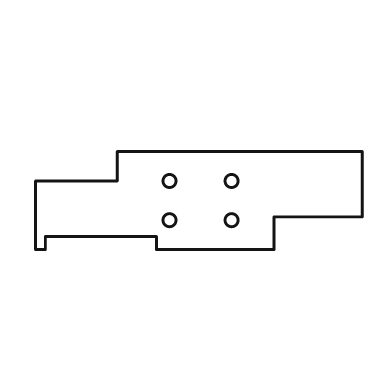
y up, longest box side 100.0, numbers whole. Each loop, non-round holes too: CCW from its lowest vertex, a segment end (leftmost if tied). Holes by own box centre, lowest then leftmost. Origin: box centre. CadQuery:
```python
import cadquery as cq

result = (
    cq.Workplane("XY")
    .moveTo(-50.0, -15.0)
    .lineTo(-47.0, -15.0)
    .lineTo(-47.0, -11.0)
    .lineTo(-13.0, -11.0)
    .lineTo(-13.0, -15.0)
    .lineTo(23.0, -15.0)
    .lineTo(23.0, -5.0)
    .lineTo(50.0, -5.0)
    .lineTo(50.0, 15.0)
    .lineTo(-25.0, 15.0)
    .lineTo(-25.0, 6.0)
    .lineTo(-50.0, 6.0)
    .close()
    .moveTo(-9.0, -6.0)
    .circle(2.0)
    .moveTo(10.0, -6.0)
    .circle(2.0)
    .moveTo(-9.0, 6.0)
    .circle(2.0)
    .moveTo(10.0, 6.0)
    .circle(2.0)
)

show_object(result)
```